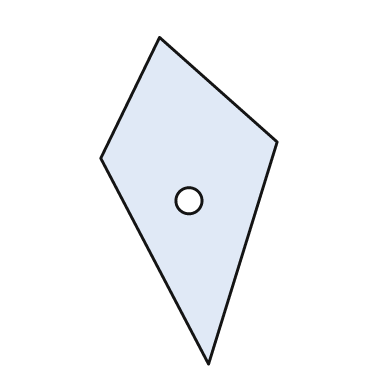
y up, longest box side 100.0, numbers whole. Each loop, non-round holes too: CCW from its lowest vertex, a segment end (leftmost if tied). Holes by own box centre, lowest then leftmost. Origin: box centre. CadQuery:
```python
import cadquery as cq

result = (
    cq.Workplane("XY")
    .moveTo(6.0, -50.0)
    .lineTo(27.0, 18.0)
    .lineTo(-9.0, 50.0)
    .lineTo(-27.0, 13.0)
    .close()
    .moveTo(0.0, 0.0)
    .circle(4.0)
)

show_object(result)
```